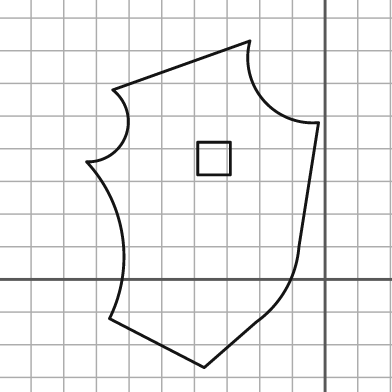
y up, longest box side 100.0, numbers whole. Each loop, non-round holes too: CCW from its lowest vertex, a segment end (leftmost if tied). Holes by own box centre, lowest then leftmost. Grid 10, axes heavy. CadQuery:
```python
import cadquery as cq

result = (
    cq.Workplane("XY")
    .moveTo(-37.0, -27.0)
    .lineTo(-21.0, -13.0)
    .threePointArc((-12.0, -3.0), (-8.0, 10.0))
    .lineTo(-2.0, 48.0)
    .threePointArc((-19.0, 55.0), (-23.0, 73.0))
    .lineTo(-65.0, 58.0)
    .threePointArc((-61.0, 44.0), (-73.0, 36.0))
    .threePointArc((-62.0, 13.0), (-66.0, -12.0))
    .close()
    .moveTo(-39.0, 32.0)
    .lineTo(-29.0, 32.0)
    .lineTo(-29.0, 42.0)
    .lineTo(-39.0, 42.0)
    .close()
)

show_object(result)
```